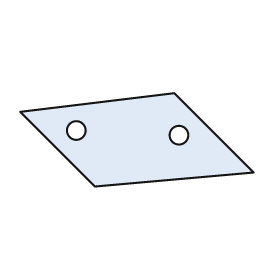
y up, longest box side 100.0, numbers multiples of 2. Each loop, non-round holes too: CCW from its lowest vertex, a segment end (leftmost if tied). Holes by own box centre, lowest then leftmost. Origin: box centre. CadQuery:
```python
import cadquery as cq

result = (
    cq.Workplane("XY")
    .moveTo(-18.0, -20.0)
    .lineTo(50.0, -14.0)
    .lineTo(16.0, 20.0)
    .lineTo(-50.0, 12.0)
    .close()
    .moveTo(18.0, 2.0)
    .circle(4.0)
    .moveTo(-26.0, 4.0)
    .circle(4.0)
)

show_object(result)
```